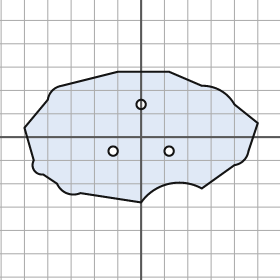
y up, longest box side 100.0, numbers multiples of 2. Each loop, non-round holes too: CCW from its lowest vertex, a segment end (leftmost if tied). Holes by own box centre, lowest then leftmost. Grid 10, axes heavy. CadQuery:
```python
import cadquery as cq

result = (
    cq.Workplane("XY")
    .moveTo(0.0, -28.0)
    .threePointArc((12.0, -20.0), (26.0, -22.0))
    .lineTo(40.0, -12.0)
    .threePointArc((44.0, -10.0), (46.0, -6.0))
    .lineTo(50.0, 6.0)
    .lineTo(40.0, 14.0)
    .threePointArc((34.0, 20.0), (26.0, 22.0))
    .lineTo(12.0, 28.0)
    .lineTo(-10.0, 28.0)
    .lineTo(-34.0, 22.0)
    .threePointArc((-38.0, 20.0), (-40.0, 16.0))
    .lineTo(-50.0, 4.0)
    .lineTo(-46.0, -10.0)
    .threePointArc((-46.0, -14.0), (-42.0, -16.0))
    .lineTo(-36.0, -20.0)
    .threePointArc((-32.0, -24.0), (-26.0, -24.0))
    .close()
    .moveTo(-12.0, -6.0)
    .circle(2.0)
    .moveTo(12.0, -6.0)
    .circle(2.0)
    .moveTo(0.0, 14.0)
    .circle(2.0)
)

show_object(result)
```